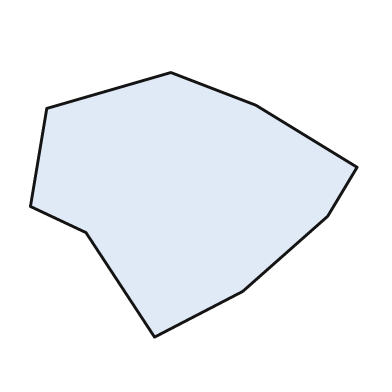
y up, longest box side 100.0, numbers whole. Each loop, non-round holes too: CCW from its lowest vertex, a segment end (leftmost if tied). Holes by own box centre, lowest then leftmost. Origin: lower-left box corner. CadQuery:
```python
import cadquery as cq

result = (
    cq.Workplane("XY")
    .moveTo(38.0, 0.0)
    .lineTo(65.0, 14.0)
    .lineTo(91.0, 37.0)
    .lineTo(100.0, 52.0)
    .lineTo(69.0, 71.0)
    .lineTo(43.0, 81.0)
    .lineTo(5.0, 70.0)
    .lineTo(0.0, 40.0)
    .lineTo(17.0, 32.0)
    .close()
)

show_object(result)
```